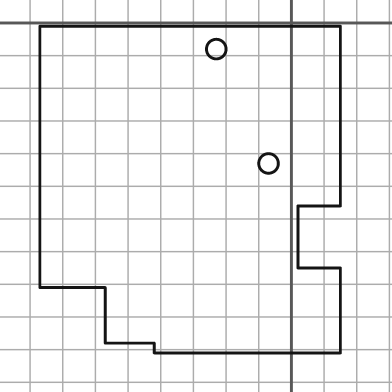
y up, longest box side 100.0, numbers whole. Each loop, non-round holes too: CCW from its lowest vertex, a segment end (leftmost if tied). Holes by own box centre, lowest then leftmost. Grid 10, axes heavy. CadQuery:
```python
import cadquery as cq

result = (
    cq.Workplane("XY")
    .moveTo(-42.0, -101.0)
    .lineTo(15.0, -101.0)
    .lineTo(15.0, -75.0)
    .lineTo(2.0, -75.0)
    .lineTo(2.0, -56.0)
    .lineTo(15.0, -56.0)
    .lineTo(15.0, -1.0)
    .lineTo(-77.0, -1.0)
    .lineTo(-77.0, -81.0)
    .lineTo(-57.0, -81.0)
    .lineTo(-57.0, -98.0)
    .lineTo(-42.0, -98.0)
    .close()
    .moveTo(-7.0, -43.0)
    .circle(3.0)
    .moveTo(-23.0, -8.0)
    .circle(3.0)
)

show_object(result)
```